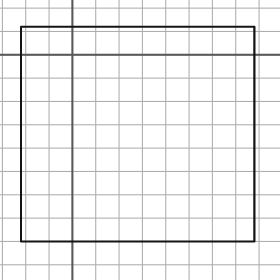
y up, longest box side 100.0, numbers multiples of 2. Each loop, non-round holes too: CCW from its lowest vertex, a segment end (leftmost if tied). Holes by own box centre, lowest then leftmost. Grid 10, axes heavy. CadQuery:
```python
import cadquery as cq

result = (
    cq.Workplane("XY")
    .moveTo(-22.0, -80.0)
    .lineTo(78.0, -80.0)
    .lineTo(78.0, 12.0)
    .lineTo(-22.0, 12.0)
    .close()
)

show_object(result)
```